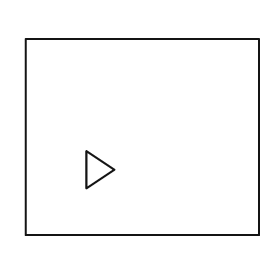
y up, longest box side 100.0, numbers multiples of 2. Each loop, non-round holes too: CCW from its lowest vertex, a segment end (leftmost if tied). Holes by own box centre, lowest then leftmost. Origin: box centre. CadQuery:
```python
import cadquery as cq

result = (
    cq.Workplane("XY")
    .moveTo(-50.0, -42.0)
    .lineTo(50.0, -42.0)
    .lineTo(50.0, 42.0)
    .lineTo(-50.0, 42.0)
    .close()
    .moveTo(-24.0, -22.0)
    .lineTo(-12.0, -14.0)
    .lineTo(-24.0, -6.0)
    .close()
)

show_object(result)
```